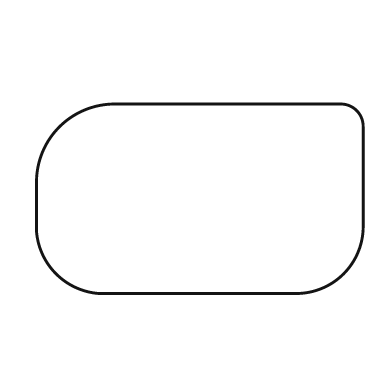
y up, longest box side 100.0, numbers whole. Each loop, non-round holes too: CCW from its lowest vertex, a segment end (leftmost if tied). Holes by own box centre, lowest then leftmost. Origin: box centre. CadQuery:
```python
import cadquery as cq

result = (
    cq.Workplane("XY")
    .moveTo(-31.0, -29.0)
    .lineTo(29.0, -29.0)
    .threePointArc((44.0, -23.0), (50.0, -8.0))
    .lineTo(50.0, 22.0)
    .threePointArc((48.0, 27.0), (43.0, 29.0))
    .lineTo(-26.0, 29.0)
    .threePointArc((-43.0, 22.0), (-50.0, 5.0))
    .lineTo(-50.0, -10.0)
    .threePointArc((-44.0, -23.0), (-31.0, -29.0))
    .close()
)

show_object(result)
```